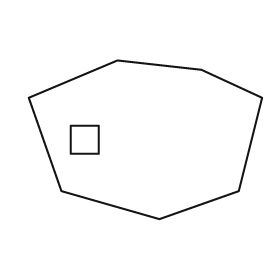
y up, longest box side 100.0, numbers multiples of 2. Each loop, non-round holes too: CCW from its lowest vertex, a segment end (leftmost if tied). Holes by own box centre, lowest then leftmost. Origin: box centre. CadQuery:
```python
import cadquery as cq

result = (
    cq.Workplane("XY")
    .moveTo(6.0, -34.0)
    .lineTo(40.0, -22.0)
    .lineTo(50.0, 18.0)
    .lineTo(24.0, 30.0)
    .lineTo(-12.0, 34.0)
    .lineTo(-50.0, 18.0)
    .lineTo(-36.0, -22.0)
    .close()
    .moveTo(-32.0, -6.0)
    .lineTo(-20.0, -6.0)
    .lineTo(-20.0, 6.0)
    .lineTo(-32.0, 6.0)
    .close()
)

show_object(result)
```